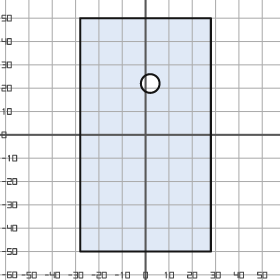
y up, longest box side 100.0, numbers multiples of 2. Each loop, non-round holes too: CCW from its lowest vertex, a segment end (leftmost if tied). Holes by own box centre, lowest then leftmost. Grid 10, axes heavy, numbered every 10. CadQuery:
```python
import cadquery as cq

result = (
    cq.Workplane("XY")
    .moveTo(-28.0, -50.0)
    .lineTo(28.0, -50.0)
    .lineTo(28.0, 50.0)
    .lineTo(-28.0, 50.0)
    .close()
    .moveTo(2.0, 22.0)
    .circle(4.0)
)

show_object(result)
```